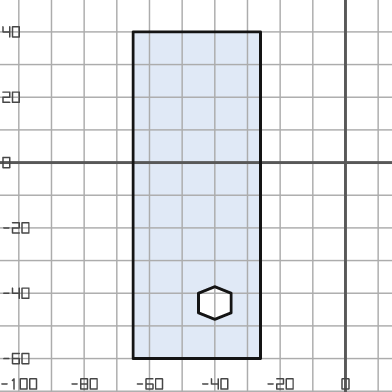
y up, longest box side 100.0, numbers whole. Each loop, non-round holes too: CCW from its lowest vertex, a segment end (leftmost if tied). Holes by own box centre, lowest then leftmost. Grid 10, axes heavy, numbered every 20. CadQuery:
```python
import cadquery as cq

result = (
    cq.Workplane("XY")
    .moveTo(-65.0, -60.0)
    .lineTo(-26.0, -60.0)
    .lineTo(-26.0, 40.0)
    .lineTo(-65.0, 40.0)
    .close()
    .moveTo(-40.0, -48.0)
    .lineTo(-35.0, -46.0)
    .lineTo(-35.0, -40.0)
    .lineTo(-40.0, -38.0)
    .lineTo(-45.0, -40.0)
    .lineTo(-45.0, -46.0)
    .close()
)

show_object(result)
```